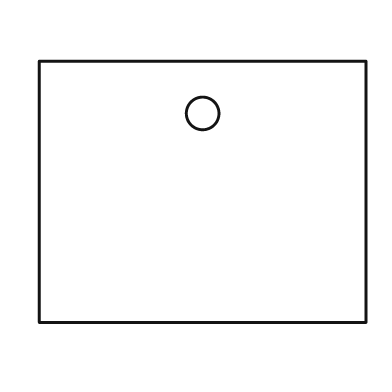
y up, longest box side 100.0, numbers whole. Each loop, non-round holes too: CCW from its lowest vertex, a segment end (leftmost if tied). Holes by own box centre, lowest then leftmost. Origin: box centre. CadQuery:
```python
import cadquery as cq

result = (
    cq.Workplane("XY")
    .moveTo(-50.0, -40.0)
    .lineTo(50.0, -40.0)
    .lineTo(50.0, 40.0)
    .lineTo(-50.0, 40.0)
    .close()
    .moveTo(0.0, 24.0)
    .circle(5.0)
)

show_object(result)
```